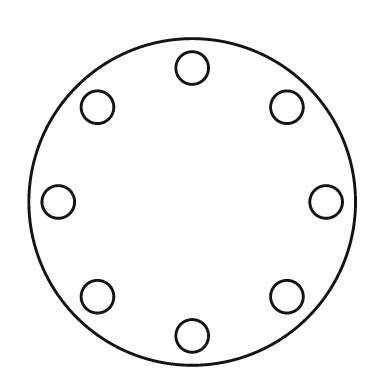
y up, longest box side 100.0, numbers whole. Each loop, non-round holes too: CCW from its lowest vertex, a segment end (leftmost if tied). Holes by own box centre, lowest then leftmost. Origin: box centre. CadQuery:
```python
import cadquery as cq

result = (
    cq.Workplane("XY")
    .moveTo(0.0, 0.0)
    .circle(50.0)
    .moveTo(0.0, -41.0)
    .circle(5.0)
    .moveTo(-29.0, -29.0)
    .circle(5.0)
    .moveTo(29.0, -29.0)
    .circle(5.0)
    .moveTo(-41.0, 0.0)
    .circle(5.0)
    .moveTo(41.0, 0.0)
    .circle(5.0)
    .moveTo(-29.0, 29.0)
    .circle(5.0)
    .moveTo(29.0, 29.0)
    .circle(5.0)
    .moveTo(0.0, 41.0)
    .circle(5.0)
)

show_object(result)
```